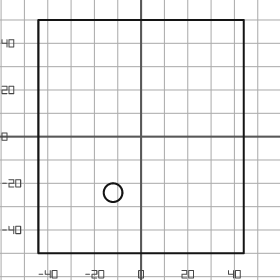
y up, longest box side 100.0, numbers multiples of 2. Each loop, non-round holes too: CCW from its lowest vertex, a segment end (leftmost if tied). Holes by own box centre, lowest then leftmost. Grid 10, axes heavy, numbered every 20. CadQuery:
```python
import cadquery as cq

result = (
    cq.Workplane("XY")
    .moveTo(-44.0, -50.0)
    .lineTo(44.0, -50.0)
    .lineTo(44.0, 50.0)
    .lineTo(-44.0, 50.0)
    .close()
    .moveTo(-12.0, -24.0)
    .circle(4.0)
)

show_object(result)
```